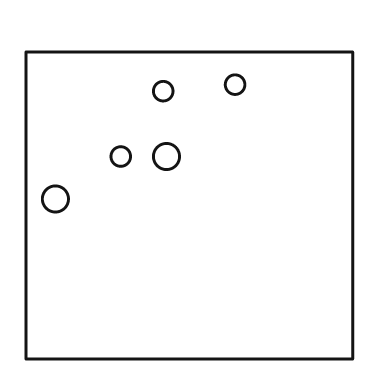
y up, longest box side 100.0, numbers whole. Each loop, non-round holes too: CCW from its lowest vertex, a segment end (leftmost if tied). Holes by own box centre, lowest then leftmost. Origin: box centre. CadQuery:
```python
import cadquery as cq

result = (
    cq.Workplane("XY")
    .moveTo(-50.0, -47.0)
    .lineTo(50.0, -47.0)
    .lineTo(50.0, 47.0)
    .lineTo(-50.0, 47.0)
    .close()
    .moveTo(-41.0, 2.0)
    .circle(4.0)
    .moveTo(-21.0, 15.0)
    .circle(3.0)
    .moveTo(-7.0, 15.0)
    .circle(4.0)
    .moveTo(-8.0, 35.0)
    .circle(3.0)
    .moveTo(14.0, 37.0)
    .circle(3.0)
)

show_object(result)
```